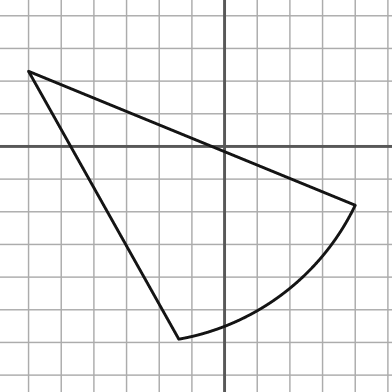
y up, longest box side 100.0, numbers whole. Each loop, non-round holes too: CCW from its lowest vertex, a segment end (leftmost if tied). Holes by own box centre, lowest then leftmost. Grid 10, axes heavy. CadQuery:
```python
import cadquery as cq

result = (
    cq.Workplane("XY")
    .moveTo(-14.0, -59.0)
    .threePointArc((18.0, -45.0), (40.0, -18.0))
    .lineTo(-60.0, 23.0)
    .close()
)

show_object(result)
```